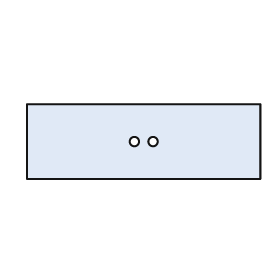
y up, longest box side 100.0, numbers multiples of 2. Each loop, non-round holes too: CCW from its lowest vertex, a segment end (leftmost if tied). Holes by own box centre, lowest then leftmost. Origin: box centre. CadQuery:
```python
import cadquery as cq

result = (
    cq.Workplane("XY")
    .moveTo(-50.0, -16.0)
    .lineTo(50.0, -16.0)
    .lineTo(50.0, 16.0)
    .lineTo(-50.0, 16.0)
    .close()
    .moveTo(-4.0, 0.0)
    .circle(2.0)
    .moveTo(4.0, 0.0)
    .circle(2.0)
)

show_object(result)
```